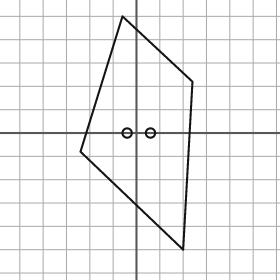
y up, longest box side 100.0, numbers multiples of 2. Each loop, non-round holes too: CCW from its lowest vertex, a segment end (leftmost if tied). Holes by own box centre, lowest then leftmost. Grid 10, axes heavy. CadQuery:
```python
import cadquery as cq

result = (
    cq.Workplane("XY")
    .moveTo(20.0, -50.0)
    .lineTo(24.0, 22.0)
    .lineTo(-6.0, 50.0)
    .lineTo(-24.0, -8.0)
    .close()
    .moveTo(-4.0, 0.0)
    .circle(2.0)
    .moveTo(6.0, 0.0)
    .circle(2.0)
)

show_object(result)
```